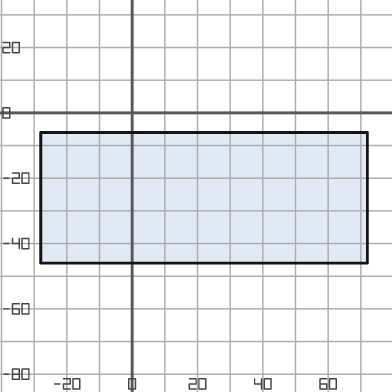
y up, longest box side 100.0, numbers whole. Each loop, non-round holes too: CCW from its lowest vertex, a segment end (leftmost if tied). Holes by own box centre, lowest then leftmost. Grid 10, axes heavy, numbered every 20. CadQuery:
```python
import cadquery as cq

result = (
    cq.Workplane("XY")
    .moveTo(-28.0, -46.0)
    .lineTo(72.0, -46.0)
    .lineTo(72.0, -6.0)
    .lineTo(-28.0, -6.0)
    .close()
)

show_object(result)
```